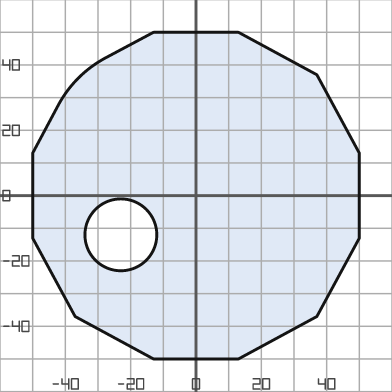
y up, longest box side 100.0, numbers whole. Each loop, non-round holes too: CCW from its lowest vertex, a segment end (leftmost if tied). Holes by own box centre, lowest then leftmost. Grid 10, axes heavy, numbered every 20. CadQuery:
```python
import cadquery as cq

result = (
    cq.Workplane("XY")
    .moveTo(-13.0, -50.0)
    .lineTo(13.0, -50.0)
    .lineTo(37.0, -37.0)
    .lineTo(50.0, -13.0)
    .lineTo(50.0, 13.0)
    .lineTo(37.0, 37.0)
    .lineTo(13.0, 50.0)
    .lineTo(-13.0, 50.0)
    .lineTo(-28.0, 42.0)
    .threePointArc((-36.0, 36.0), (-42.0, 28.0))
    .lineTo(-50.0, 13.0)
    .lineTo(-50.0, -13.0)
    .lineTo(-37.0, -37.0)
    .close()
    .moveTo(-23.0, -12.0)
    .circle(11.0)
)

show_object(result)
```